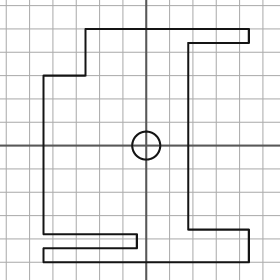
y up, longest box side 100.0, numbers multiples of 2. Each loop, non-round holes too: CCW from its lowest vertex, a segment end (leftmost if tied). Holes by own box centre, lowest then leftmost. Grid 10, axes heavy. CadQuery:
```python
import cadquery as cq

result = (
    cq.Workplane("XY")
    .moveTo(-44.0, -50.0)
    .lineTo(44.0, -50.0)
    .lineTo(44.0, -36.0)
    .lineTo(18.0, -36.0)
    .lineTo(18.0, 44.0)
    .lineTo(44.0, 44.0)
    .lineTo(44.0, 50.0)
    .lineTo(-26.0, 50.0)
    .lineTo(-26.0, 30.0)
    .lineTo(-44.0, 30.0)
    .lineTo(-44.0, -38.0)
    .lineTo(-4.0, -38.0)
    .lineTo(-4.0, -44.0)
    .lineTo(-44.0, -44.0)
    .close()
    .moveTo(0.0, 0.0)
    .circle(6.0)
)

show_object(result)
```